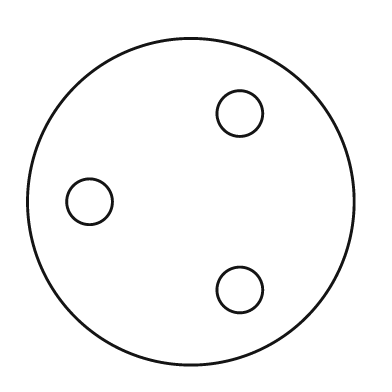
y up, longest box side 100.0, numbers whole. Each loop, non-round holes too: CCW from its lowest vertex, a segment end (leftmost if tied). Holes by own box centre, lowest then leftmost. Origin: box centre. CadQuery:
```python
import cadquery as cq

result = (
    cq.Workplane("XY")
    .moveTo(0.0, 0.0)
    .circle(50.0)
    .moveTo(15.0, -27.0)
    .circle(7.0)
    .moveTo(-31.0, 0.0)
    .circle(7.0)
    .moveTo(15.0, 27.0)
    .circle(7.0)
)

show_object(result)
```